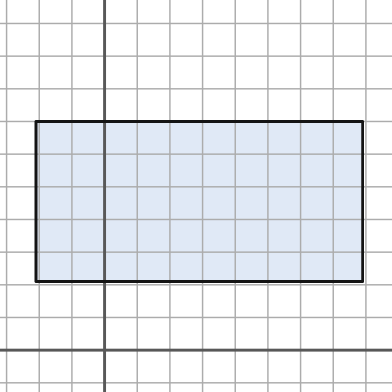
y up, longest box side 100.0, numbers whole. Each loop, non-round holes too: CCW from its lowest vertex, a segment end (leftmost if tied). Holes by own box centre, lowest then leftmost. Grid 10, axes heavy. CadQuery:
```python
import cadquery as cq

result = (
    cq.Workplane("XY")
    .moveTo(-21.0, 21.0)
    .lineTo(79.0, 21.0)
    .lineTo(79.0, 70.0)
    .lineTo(-21.0, 70.0)
    .close()
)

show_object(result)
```